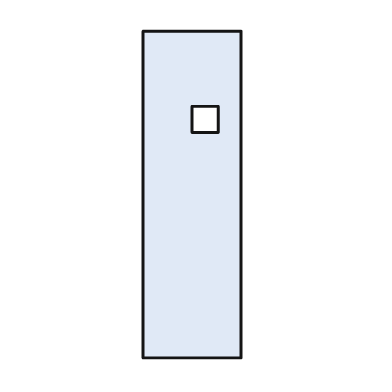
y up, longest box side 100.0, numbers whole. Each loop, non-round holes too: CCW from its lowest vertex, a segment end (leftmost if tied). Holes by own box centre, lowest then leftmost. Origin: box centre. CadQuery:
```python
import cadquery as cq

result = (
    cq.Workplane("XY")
    .moveTo(-15.0, -50.0)
    .lineTo(15.0, -50.0)
    .lineTo(15.0, 50.0)
    .lineTo(-15.0, 50.0)
    .close()
    .moveTo(0.0, 19.0)
    .lineTo(8.0, 19.0)
    .lineTo(8.0, 27.0)
    .lineTo(0.0, 27.0)
    .close()
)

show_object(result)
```